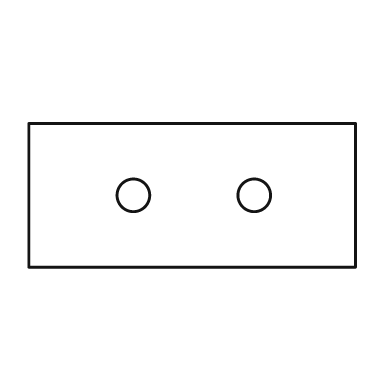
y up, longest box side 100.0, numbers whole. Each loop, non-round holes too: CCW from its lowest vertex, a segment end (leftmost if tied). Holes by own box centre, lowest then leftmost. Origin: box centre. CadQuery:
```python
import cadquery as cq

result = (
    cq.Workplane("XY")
    .moveTo(-50.0, -22.0)
    .lineTo(50.0, -22.0)
    .lineTo(50.0, 22.0)
    .lineTo(-50.0, 22.0)
    .close()
    .moveTo(-18.0, 0.0)
    .circle(5.0)
    .moveTo(19.0, 0.0)
    .circle(5.0)
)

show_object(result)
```